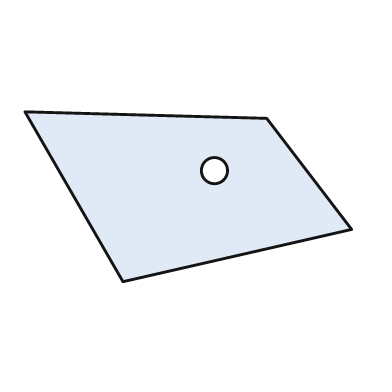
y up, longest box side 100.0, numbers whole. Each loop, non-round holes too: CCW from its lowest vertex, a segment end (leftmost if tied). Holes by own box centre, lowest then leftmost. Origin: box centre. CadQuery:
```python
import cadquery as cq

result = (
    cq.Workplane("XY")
    .moveTo(-20.0, -26.0)
    .lineTo(50.0, -10.0)
    .lineTo(24.0, 24.0)
    .lineTo(-50.0, 26.0)
    .close()
    .moveTo(8.0, 8.0)
    .circle(4.0)
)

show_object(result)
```